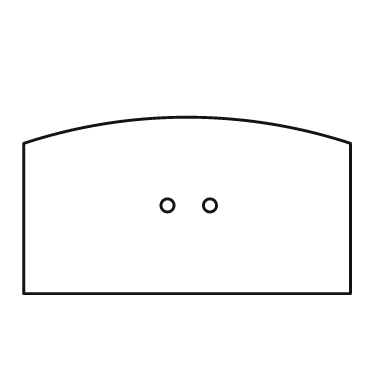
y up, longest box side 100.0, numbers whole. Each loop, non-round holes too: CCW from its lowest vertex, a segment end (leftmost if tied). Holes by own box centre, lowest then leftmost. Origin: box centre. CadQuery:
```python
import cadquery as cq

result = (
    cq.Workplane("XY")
    .moveTo(-50.0, -27.0)
    .lineTo(50.0, -27.0)
    .lineTo(50.0, 19.0)
    .threePointArc((0.0, 27.0), (-50.0, 19.0))
    .close()
    .moveTo(-6.0, 0.0)
    .circle(2.0)
    .moveTo(7.0, 0.0)
    .circle(2.0)
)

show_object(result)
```